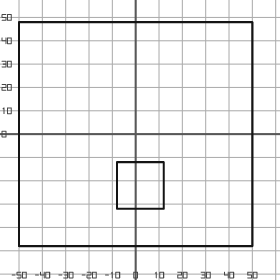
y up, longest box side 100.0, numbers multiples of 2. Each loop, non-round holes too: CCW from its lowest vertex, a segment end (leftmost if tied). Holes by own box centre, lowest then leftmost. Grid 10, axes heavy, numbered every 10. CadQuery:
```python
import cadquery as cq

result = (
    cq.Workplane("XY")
    .moveTo(-50.0, -48.0)
    .lineTo(50.0, -48.0)
    .lineTo(50.0, 48.0)
    .lineTo(-50.0, 48.0)
    .close()
    .moveTo(-8.0, -32.0)
    .lineTo(12.0, -32.0)
    .lineTo(12.0, -12.0)
    .lineTo(-8.0, -12.0)
    .close()
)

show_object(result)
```